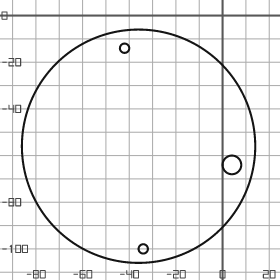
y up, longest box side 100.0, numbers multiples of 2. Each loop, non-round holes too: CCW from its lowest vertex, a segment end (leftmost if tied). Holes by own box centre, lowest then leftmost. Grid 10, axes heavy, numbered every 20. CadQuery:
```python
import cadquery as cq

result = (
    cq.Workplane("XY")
    .moveTo(-36.0, -56.0)
    .circle(50.0)
    .moveTo(-34.0, -100.0)
    .circle(2.0)
    .moveTo(4.0, -64.0)
    .circle(4.0)
    .moveTo(-42.0, -14.0)
    .circle(2.0)
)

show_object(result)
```